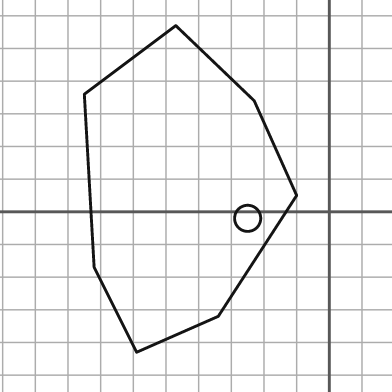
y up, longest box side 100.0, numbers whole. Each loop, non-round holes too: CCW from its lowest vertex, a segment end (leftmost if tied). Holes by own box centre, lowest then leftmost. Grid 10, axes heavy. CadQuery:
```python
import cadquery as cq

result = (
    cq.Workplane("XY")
    .moveTo(-59.0, -43.0)
    .lineTo(-34.0, -32.0)
    .lineTo(-10.0, 5.0)
    .lineTo(-23.0, 34.0)
    .lineTo(-47.0, 57.0)
    .lineTo(-75.0, 36.0)
    .lineTo(-72.0, -17.0)
    .close()
    .moveTo(-25.0, -2.0)
    .circle(4.0)
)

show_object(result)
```